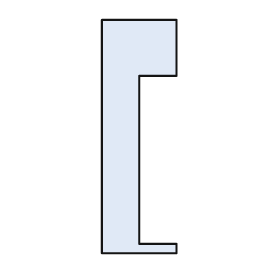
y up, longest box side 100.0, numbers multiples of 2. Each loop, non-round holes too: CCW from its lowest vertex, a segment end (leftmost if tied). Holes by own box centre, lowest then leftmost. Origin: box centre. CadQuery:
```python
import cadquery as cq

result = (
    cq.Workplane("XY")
    .moveTo(-16.0, -50.0)
    .lineTo(16.0, -50.0)
    .lineTo(16.0, -46.0)
    .lineTo(0.0, -46.0)
    .lineTo(0.0, 26.0)
    .lineTo(16.0, 26.0)
    .lineTo(16.0, 50.0)
    .lineTo(-16.0, 50.0)
    .close()
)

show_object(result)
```